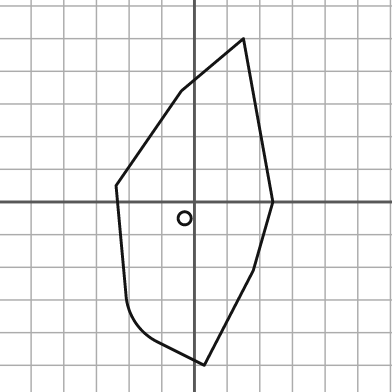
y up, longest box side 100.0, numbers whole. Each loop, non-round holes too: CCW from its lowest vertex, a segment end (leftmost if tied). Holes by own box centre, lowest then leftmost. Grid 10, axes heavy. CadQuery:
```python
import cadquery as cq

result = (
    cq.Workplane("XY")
    .moveTo(3.0, -50.0)
    .lineTo(18.0, -21.0)
    .lineTo(24.0, 0.0)
    .lineTo(15.0, 50.0)
    .lineTo(-4.0, 34.0)
    .lineTo(-24.0, 5.0)
    .lineTo(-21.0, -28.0)
    .threePointArc((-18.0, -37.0), (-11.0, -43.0))
    .close()
    .moveTo(-3.0, -5.0)
    .circle(2.0)
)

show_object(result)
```